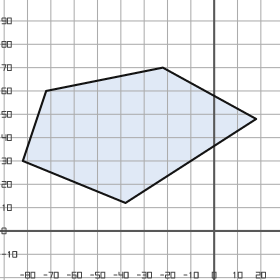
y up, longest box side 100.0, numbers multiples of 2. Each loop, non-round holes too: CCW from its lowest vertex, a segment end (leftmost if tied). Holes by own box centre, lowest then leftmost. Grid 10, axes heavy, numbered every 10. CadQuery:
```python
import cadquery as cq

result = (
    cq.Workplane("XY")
    .moveTo(-38.0, 12.0)
    .lineTo(18.0, 48.0)
    .lineTo(-22.0, 70.0)
    .lineTo(-72.0, 60.0)
    .lineTo(-82.0, 30.0)
    .close()
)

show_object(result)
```